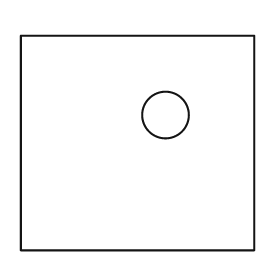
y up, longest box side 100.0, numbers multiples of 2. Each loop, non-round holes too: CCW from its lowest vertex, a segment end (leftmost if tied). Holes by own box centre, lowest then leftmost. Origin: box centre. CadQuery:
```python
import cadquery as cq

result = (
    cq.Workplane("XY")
    .moveTo(-50.0, -46.0)
    .lineTo(50.0, -46.0)
    .lineTo(50.0, 46.0)
    .lineTo(-50.0, 46.0)
    .close()
    .moveTo(12.0, 12.0)
    .circle(10.0)
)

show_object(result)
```